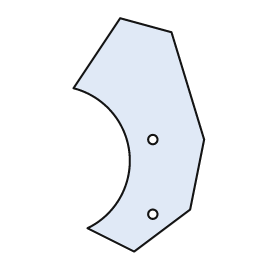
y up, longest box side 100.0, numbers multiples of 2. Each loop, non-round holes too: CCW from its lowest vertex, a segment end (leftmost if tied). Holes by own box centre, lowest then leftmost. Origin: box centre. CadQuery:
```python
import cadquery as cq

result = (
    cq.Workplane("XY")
    .moveTo(-2.0, -50.0)
    .lineTo(22.0, -32.0)
    .lineTo(28.0, -2.0)
    .lineTo(14.0, 44.0)
    .lineTo(-8.0, 50.0)
    .lineTo(-28.0, 20.0)
    .threePointArc((-4.0, -8.0), (-22.0, -40.0))
    .close()
    .moveTo(6.0, -34.0)
    .circle(2.0)
    .moveTo(6.0, -2.0)
    .circle(2.0)
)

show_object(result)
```